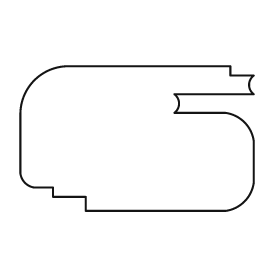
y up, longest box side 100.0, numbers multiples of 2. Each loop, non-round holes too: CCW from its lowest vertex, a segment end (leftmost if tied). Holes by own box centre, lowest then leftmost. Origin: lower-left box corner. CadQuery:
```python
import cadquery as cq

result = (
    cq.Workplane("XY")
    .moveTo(28.0, 0.0)
    .lineTo(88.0, 0.0)
    .threePointArc((96.0, 4.0), (100.0, 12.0))
    .lineTo(100.0, 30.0)
    .threePointArc((96.0, 38.0), (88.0, 42.0))
    .lineTo(66.0, 42.0)
    .threePointArc((68.0, 46.0), (66.0, 50.0))
    .lineTo(100.0, 50.0)
    .threePointArc((98.0, 54.0), (100.0, 58.0))
    .lineTo(90.0, 58.0)
    .lineTo(90.0, 62.0)
    .lineTo(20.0, 62.0)
    .threePointArc((6.0, 56.0), (0.0, 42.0))
    .lineTo(0.0, 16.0)
    .threePointArc((2.0, 12.0), (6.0, 10.0))
    .lineTo(14.0, 10.0)
    .lineTo(14.0, 6.0)
    .lineTo(28.0, 6.0)
    .close()
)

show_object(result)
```